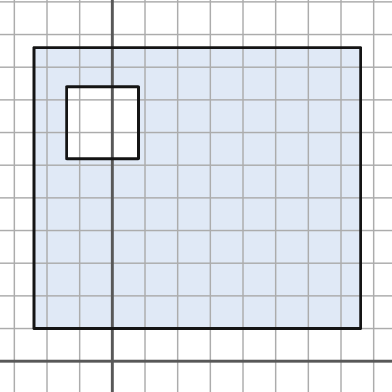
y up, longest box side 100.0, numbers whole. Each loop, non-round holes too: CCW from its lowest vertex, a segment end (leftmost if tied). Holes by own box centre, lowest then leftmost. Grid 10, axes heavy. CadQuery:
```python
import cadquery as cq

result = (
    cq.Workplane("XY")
    .moveTo(-24.0, 10.0)
    .lineTo(76.0, 10.0)
    .lineTo(76.0, 96.0)
    .lineTo(-24.0, 96.0)
    .close()
    .moveTo(-14.0, 62.0)
    .lineTo(8.0, 62.0)
    .lineTo(8.0, 84.0)
    .lineTo(-14.0, 84.0)
    .close()
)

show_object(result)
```